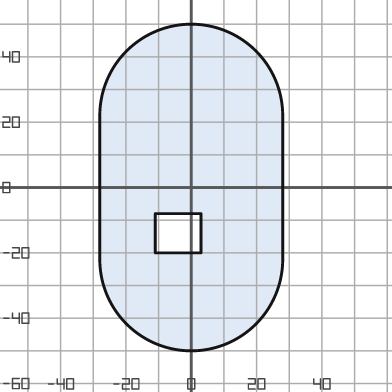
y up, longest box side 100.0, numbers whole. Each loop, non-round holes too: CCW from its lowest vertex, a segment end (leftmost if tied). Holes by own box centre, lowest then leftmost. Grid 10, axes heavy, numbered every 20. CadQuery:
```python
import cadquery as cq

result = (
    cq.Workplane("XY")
    .moveTo(-28.0, -22.0)
    .threePointArc((0.0, -50.0), (28.0, -22.0))
    .lineTo(28.0, 22.0)
    .threePointArc((0.0, 50.0), (-28.0, 22.0))
    .close()
    .moveTo(-11.0, -20.0)
    .lineTo(3.0, -20.0)
    .lineTo(3.0, -8.0)
    .lineTo(-11.0, -8.0)
    .close()
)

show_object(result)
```